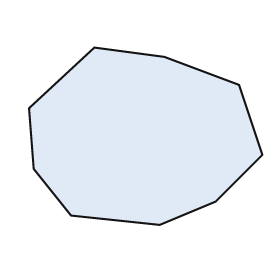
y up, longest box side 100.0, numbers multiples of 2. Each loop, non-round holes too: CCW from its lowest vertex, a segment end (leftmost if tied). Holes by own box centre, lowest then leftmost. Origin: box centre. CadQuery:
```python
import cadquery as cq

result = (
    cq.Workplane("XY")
    .moveTo(6.0, -38.0)
    .lineTo(30.0, -28.0)
    .lineTo(50.0, -8.0)
    .lineTo(40.0, 22.0)
    .lineTo(8.0, 34.0)
    .lineTo(-22.0, 38.0)
    .lineTo(-50.0, 12.0)
    .lineTo(-48.0, -14.0)
    .lineTo(-32.0, -34.0)
    .close()
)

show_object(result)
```